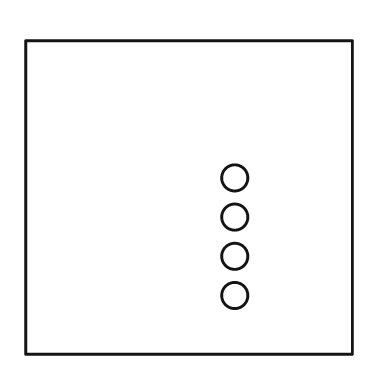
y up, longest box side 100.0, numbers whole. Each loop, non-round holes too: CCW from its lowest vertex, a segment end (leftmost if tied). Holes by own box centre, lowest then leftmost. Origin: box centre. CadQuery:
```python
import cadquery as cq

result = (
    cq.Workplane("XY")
    .moveTo(-50.0, -48.0)
    .lineTo(50.0, -48.0)
    .lineTo(50.0, 48.0)
    .lineTo(-50.0, 48.0)
    .close()
    .moveTo(14.0, -30.0)
    .circle(4.0)
    .moveTo(14.0, -18.0)
    .circle(4.0)
    .moveTo(14.0, -6.0)
    .circle(4.0)
    .moveTo(14.0, 6.0)
    .circle(4.0)
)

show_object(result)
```